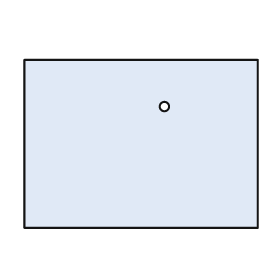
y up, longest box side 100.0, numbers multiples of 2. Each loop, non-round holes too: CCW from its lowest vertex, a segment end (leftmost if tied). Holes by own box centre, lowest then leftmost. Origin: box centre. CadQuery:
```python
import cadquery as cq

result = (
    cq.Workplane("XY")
    .moveTo(-50.0, -36.0)
    .lineTo(50.0, -36.0)
    .lineTo(50.0, 36.0)
    .lineTo(-50.0, 36.0)
    .close()
    .moveTo(10.0, 16.0)
    .circle(2.0)
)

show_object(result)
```